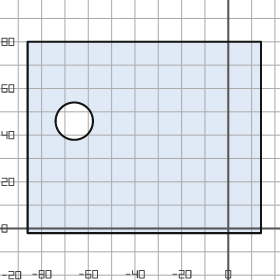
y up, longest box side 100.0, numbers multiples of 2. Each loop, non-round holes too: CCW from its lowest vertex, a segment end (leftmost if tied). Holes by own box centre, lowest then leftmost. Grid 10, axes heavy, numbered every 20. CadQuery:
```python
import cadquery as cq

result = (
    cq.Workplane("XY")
    .moveTo(-86.0, -2.0)
    .lineTo(14.0, -2.0)
    .lineTo(14.0, 80.0)
    .lineTo(-86.0, 80.0)
    .close()
    .moveTo(-66.0, 46.0)
    .circle(8.0)
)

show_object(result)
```